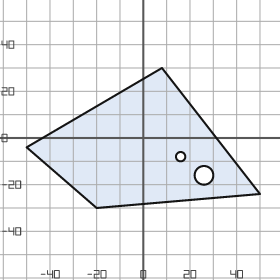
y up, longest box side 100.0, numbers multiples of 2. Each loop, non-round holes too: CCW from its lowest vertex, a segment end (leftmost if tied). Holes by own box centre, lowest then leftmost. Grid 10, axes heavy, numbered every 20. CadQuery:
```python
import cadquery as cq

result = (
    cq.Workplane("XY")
    .moveTo(-20.0, -30.0)
    .lineTo(50.0, -24.0)
    .lineTo(8.0, 30.0)
    .lineTo(-50.0, -4.0)
    .close()
    .moveTo(26.0, -16.0)
    .circle(4.0)
    .moveTo(16.0, -8.0)
    .circle(2.0)
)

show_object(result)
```